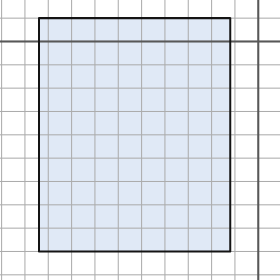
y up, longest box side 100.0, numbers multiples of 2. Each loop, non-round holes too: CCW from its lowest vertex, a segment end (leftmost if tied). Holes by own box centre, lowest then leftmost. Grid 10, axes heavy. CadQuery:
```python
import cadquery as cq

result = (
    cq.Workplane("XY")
    .moveTo(-94.0, -90.0)
    .lineTo(-12.0, -90.0)
    .lineTo(-12.0, 10.0)
    .lineTo(-94.0, 10.0)
    .close()
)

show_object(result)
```